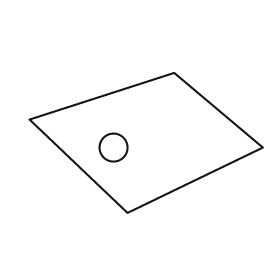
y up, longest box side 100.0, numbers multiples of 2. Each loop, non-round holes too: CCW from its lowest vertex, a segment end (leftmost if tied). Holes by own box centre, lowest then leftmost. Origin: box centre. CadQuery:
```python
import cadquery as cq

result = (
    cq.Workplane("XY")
    .moveTo(-8.0, -30.0)
    .lineTo(50.0, -2.0)
    .lineTo(12.0, 30.0)
    .lineTo(-50.0, 10.0)
    .close()
    .moveTo(-14.0, -2.0)
    .circle(6.0)
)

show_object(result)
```